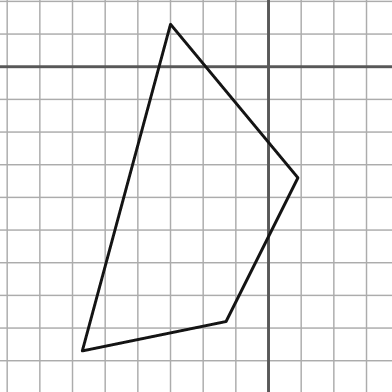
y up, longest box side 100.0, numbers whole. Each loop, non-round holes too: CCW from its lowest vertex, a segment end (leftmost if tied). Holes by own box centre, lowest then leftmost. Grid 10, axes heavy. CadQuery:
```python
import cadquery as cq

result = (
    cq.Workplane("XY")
    .moveTo(-57.0, -87.0)
    .lineTo(-13.0, -78.0)
    .lineTo(9.0, -34.0)
    .lineTo(-30.0, 13.0)
    .close()
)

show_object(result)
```